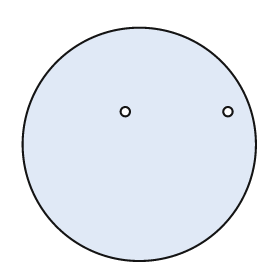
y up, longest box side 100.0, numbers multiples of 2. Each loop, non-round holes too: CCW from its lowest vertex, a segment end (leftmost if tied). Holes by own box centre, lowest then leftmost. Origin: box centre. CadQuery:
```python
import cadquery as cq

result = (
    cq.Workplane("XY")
    .moveTo(0.0, 0.0)
    .circle(50.0)
    .moveTo(-6.0, 14.0)
    .circle(2.0)
    .moveTo(38.0, 14.0)
    .circle(2.0)
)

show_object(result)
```